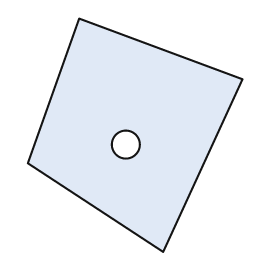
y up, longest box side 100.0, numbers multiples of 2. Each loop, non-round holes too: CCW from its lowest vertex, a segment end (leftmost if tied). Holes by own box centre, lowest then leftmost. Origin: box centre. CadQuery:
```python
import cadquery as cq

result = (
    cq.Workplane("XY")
    .moveTo(12.0, -50.0)
    .lineTo(46.0, 24.0)
    .lineTo(-24.0, 50.0)
    .lineTo(-46.0, -12.0)
    .close()
    .moveTo(-4.0, -4.0)
    .circle(6.0)
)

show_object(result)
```